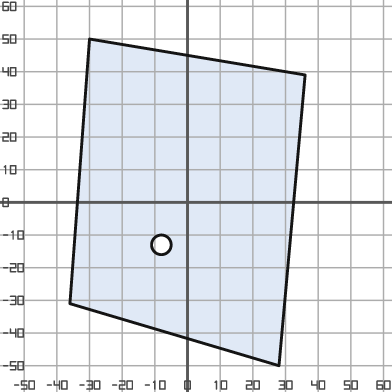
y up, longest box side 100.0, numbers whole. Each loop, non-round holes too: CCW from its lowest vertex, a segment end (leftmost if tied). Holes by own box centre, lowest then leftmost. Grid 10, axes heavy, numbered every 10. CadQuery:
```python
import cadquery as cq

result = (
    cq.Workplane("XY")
    .moveTo(28.0, -50.0)
    .lineTo(36.0, 39.0)
    .lineTo(-30.0, 50.0)
    .lineTo(-36.0, -31.0)
    .close()
    .moveTo(-8.0, -13.0)
    .circle(3.0)
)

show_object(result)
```